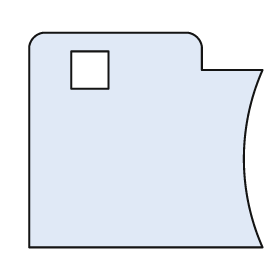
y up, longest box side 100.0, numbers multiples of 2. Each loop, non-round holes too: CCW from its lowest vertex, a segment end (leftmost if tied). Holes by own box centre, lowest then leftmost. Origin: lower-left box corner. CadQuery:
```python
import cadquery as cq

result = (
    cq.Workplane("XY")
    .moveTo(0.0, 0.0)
    .lineTo(100.0, 0.0)
    .threePointArc((92.0, 38.0), (100.0, 76.0))
    .lineTo(74.0, 76.0)
    .lineTo(74.0, 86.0)
    .threePointArc((72.0, 90.0), (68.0, 92.0))
    .lineTo(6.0, 92.0)
    .threePointArc((2.0, 90.0), (0.0, 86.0))
    .close()
    .moveTo(18.0, 68.0)
    .lineTo(34.0, 68.0)
    .lineTo(34.0, 84.0)
    .lineTo(18.0, 84.0)
    .close()
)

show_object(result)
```